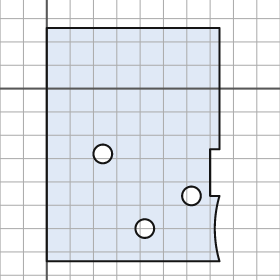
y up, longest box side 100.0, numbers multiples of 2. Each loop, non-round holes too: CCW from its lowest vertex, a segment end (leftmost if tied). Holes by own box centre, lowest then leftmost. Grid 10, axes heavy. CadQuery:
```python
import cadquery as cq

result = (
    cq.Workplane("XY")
    .moveTo(0.0, -74.0)
    .lineTo(74.0, -74.0)
    .threePointArc((72.0, -60.0), (74.0, -46.0))
    .lineTo(70.0, -46.0)
    .lineTo(70.0, -26.0)
    .lineTo(74.0, -26.0)
    .lineTo(74.0, 26.0)
    .lineTo(0.0, 26.0)
    .close()
    .moveTo(42.0, -60.0)
    .circle(4.0)
    .moveTo(62.0, -46.0)
    .circle(4.0)
    .moveTo(24.0, -28.0)
    .circle(4.0)
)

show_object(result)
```